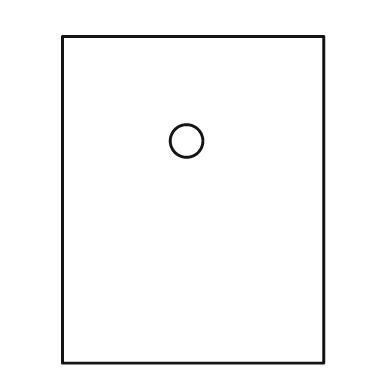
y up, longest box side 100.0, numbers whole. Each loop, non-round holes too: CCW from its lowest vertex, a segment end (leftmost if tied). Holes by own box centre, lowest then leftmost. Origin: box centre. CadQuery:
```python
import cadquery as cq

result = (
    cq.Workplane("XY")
    .moveTo(-40.0, -50.0)
    .lineTo(40.0, -50.0)
    .lineTo(40.0, 50.0)
    .lineTo(-40.0, 50.0)
    .close()
    .moveTo(-2.0, 18.0)
    .circle(5.0)
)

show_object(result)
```